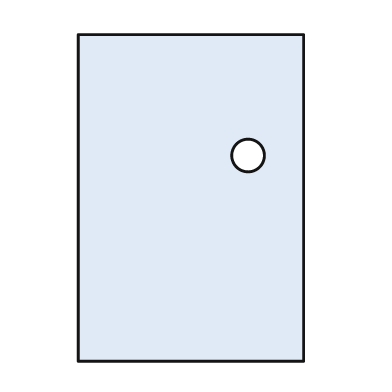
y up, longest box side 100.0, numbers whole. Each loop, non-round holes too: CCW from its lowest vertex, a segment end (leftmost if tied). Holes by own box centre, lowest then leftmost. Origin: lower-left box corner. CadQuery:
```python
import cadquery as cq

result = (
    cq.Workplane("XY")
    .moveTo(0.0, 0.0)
    .lineTo(69.0, 0.0)
    .lineTo(69.0, 100.0)
    .lineTo(0.0, 100.0)
    .close()
    .moveTo(52.0, 63.0)
    .circle(5.0)
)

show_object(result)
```